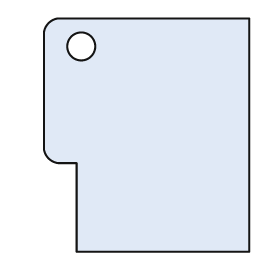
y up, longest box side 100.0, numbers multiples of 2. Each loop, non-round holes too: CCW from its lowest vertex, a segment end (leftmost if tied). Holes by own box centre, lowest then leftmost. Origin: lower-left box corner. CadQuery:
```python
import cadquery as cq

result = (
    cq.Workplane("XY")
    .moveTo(14.0, 0.0)
    .lineTo(88.0, 0.0)
    .lineTo(88.0, 100.0)
    .lineTo(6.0, 100.0)
    .threePointArc((2.0, 98.0), (0.0, 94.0))
    .lineTo(0.0, 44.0)
    .threePointArc((2.0, 40.0), (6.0, 38.0))
    .lineTo(14.0, 38.0)
    .close()
    .moveTo(16.0, 88.0)
    .circle(6.0)
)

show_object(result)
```